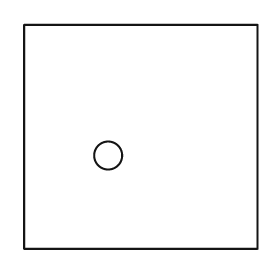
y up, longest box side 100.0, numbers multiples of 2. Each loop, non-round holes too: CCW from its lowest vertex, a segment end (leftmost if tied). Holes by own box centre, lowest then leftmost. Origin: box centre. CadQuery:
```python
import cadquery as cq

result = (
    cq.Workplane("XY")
    .moveTo(-50.0, -48.0)
    .lineTo(50.0, -48.0)
    .lineTo(50.0, 48.0)
    .lineTo(-50.0, 48.0)
    .close()
    .moveTo(-14.0, -8.0)
    .circle(6.0)
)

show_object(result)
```